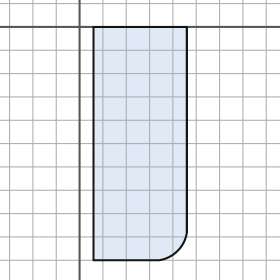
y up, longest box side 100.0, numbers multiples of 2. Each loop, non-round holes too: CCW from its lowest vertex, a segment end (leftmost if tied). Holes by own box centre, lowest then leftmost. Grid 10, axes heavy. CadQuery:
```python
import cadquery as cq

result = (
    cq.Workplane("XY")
    .moveTo(6.0, -100.0)
    .lineTo(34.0, -100.0)
    .threePointArc((42.0, -96.0), (46.0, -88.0))
    .lineTo(46.0, 0.0)
    .lineTo(6.0, 0.0)
    .close()
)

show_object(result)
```